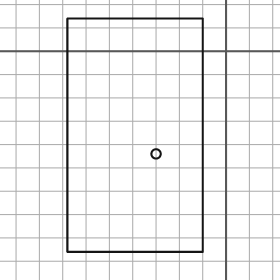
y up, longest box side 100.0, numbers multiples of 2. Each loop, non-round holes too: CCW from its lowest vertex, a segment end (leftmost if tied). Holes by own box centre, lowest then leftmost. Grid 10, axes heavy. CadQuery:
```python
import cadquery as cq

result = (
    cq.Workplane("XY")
    .moveTo(-68.0, -86.0)
    .lineTo(-10.0, -86.0)
    .lineTo(-10.0, 14.0)
    .lineTo(-68.0, 14.0)
    .close()
    .moveTo(-30.0, -44.0)
    .circle(2.0)
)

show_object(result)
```